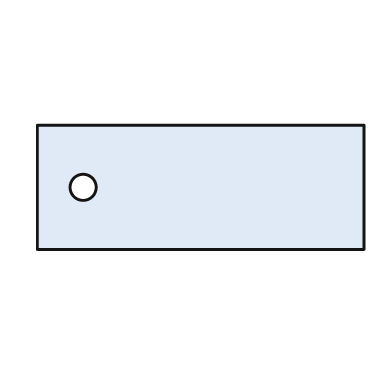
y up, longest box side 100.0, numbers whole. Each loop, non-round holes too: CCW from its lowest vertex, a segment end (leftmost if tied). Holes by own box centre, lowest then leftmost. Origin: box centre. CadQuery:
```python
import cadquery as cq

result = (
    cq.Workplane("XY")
    .moveTo(-50.0, -19.0)
    .lineTo(50.0, -19.0)
    .lineTo(50.0, 19.0)
    .lineTo(-50.0, 19.0)
    .close()
    .moveTo(-36.0, 0.0)
    .circle(4.0)
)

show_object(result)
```